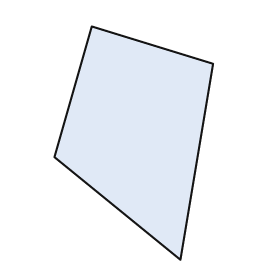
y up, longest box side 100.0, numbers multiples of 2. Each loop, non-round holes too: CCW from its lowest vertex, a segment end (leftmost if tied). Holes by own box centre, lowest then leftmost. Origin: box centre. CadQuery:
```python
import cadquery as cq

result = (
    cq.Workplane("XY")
    .moveTo(20.0, -50.0)
    .lineTo(34.0, 34.0)
    .lineTo(-18.0, 50.0)
    .lineTo(-34.0, -6.0)
    .close()
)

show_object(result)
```